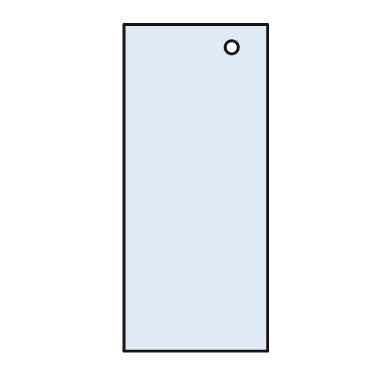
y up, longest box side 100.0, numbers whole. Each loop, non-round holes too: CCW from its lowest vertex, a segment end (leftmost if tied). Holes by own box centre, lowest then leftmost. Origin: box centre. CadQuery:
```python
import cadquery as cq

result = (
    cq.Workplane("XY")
    .moveTo(-22.0, -50.0)
    .lineTo(22.0, -50.0)
    .lineTo(22.0, 50.0)
    .lineTo(-22.0, 50.0)
    .close()
    .moveTo(11.0, 43.0)
    .circle(2.0)
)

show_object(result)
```